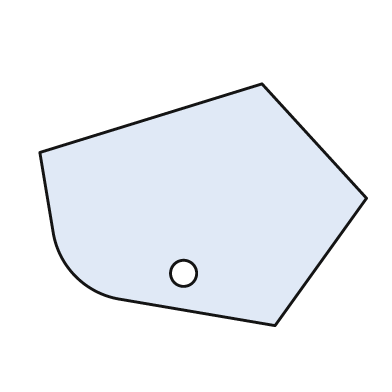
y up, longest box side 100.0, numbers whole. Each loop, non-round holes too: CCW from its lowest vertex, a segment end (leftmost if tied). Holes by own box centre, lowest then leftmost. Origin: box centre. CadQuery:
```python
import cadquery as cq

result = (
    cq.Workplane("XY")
    .moveTo(22.0, -37.0)
    .lineTo(50.0, 2.0)
    .lineTo(18.0, 37.0)
    .lineTo(-50.0, 16.0)
    .lineTo(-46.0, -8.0)
    .threePointArc((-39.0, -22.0), (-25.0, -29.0))
    .close()
    .moveTo(-6.0, -21.0)
    .circle(4.0)
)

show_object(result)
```